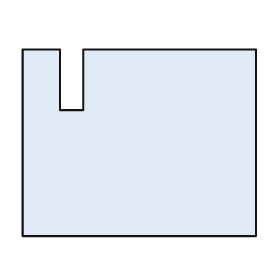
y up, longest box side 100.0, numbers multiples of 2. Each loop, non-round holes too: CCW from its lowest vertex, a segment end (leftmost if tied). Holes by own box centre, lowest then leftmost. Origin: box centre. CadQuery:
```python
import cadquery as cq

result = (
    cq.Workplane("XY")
    .moveTo(-50.0, -40.0)
    .lineTo(50.0, -40.0)
    .lineTo(50.0, 40.0)
    .lineTo(-24.0, 40.0)
    .lineTo(-24.0, 14.0)
    .lineTo(-34.0, 14.0)
    .lineTo(-34.0, 40.0)
    .lineTo(-50.0, 40.0)
    .close()
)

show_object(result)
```